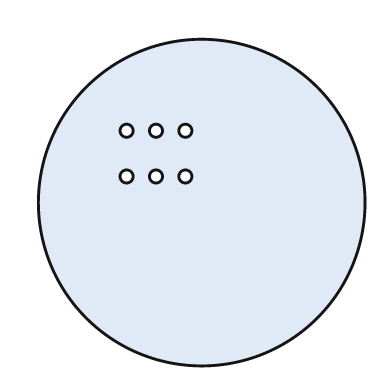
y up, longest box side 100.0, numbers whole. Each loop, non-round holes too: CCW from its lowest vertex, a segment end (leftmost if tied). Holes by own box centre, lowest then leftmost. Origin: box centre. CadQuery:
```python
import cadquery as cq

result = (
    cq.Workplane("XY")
    .moveTo(0.0, 0.0)
    .circle(50.0)
    .moveTo(-23.0, 8.0)
    .circle(2.0)
    .moveTo(-14.0, 8.0)
    .circle(2.0)
    .moveTo(-5.0, 8.0)
    .circle(2.0)
    .moveTo(-23.0, 22.0)
    .circle(2.0)
    .moveTo(-14.0, 22.0)
    .circle(2.0)
    .moveTo(-5.0, 22.0)
    .circle(2.0)
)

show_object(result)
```